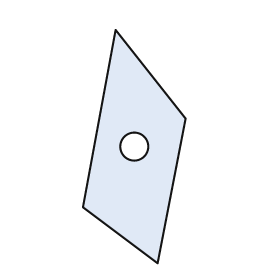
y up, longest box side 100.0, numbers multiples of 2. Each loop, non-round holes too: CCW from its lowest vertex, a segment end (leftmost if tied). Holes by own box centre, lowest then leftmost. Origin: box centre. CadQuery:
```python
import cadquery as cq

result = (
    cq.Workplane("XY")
    .moveTo(10.0, -50.0)
    .lineTo(22.0, 12.0)
    .lineTo(-8.0, 50.0)
    .lineTo(-22.0, -26.0)
    .close()
    .moveTo(0.0, 0.0)
    .circle(6.0)
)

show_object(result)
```